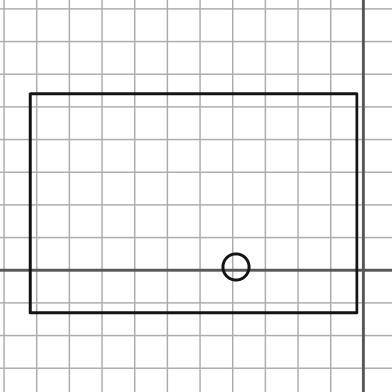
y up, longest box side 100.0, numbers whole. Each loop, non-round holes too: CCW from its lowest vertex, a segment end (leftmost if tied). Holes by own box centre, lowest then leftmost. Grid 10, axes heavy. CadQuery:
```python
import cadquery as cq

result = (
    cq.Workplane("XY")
    .moveTo(-102.0, -13.0)
    .lineTo(-2.0, -13.0)
    .lineTo(-2.0, 54.0)
    .lineTo(-102.0, 54.0)
    .close()
    .moveTo(-39.0, 1.0)
    .circle(4.0)
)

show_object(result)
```